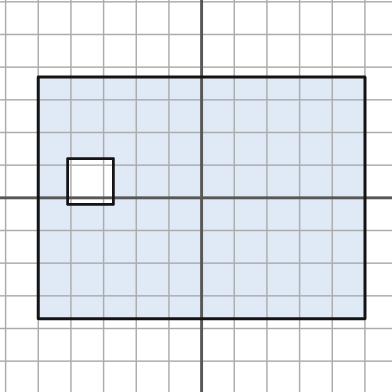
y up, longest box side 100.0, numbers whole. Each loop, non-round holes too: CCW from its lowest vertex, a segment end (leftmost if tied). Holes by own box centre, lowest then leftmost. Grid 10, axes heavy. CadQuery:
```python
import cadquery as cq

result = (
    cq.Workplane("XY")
    .moveTo(-50.0, -37.0)
    .lineTo(50.0, -37.0)
    .lineTo(50.0, 37.0)
    .lineTo(-50.0, 37.0)
    .close()
    .moveTo(-41.0, -2.0)
    .lineTo(-27.0, -2.0)
    .lineTo(-27.0, 12.0)
    .lineTo(-41.0, 12.0)
    .close()
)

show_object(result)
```